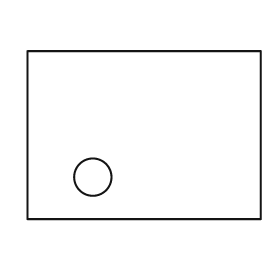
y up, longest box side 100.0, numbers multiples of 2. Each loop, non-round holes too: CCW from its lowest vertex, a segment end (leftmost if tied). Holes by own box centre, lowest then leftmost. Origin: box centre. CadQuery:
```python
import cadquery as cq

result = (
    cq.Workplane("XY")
    .moveTo(-50.0, -36.0)
    .lineTo(50.0, -36.0)
    .lineTo(50.0, 36.0)
    .lineTo(-50.0, 36.0)
    .close()
    .moveTo(-22.0, -18.0)
    .circle(8.0)
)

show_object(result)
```